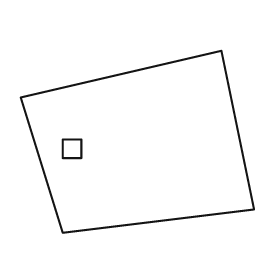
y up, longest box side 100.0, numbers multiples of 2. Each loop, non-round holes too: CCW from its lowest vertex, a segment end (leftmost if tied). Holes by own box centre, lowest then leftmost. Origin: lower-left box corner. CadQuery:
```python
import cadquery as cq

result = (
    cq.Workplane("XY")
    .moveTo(18.0, 0.0)
    .lineTo(100.0, 10.0)
    .lineTo(86.0, 78.0)
    .lineTo(0.0, 58.0)
    .close()
    .moveTo(18.0, 32.0)
    .lineTo(26.0, 32.0)
    .lineTo(26.0, 40.0)
    .lineTo(18.0, 40.0)
    .close()
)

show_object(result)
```